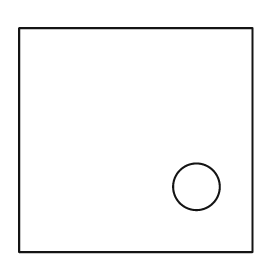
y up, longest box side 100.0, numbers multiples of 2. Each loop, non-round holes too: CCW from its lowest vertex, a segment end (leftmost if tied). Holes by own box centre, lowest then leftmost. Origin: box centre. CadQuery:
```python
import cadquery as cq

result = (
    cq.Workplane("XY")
    .moveTo(-50.0, -48.0)
    .lineTo(50.0, -48.0)
    .lineTo(50.0, 48.0)
    .lineTo(-50.0, 48.0)
    .close()
    .moveTo(26.0, -20.0)
    .circle(10.0)
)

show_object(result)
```